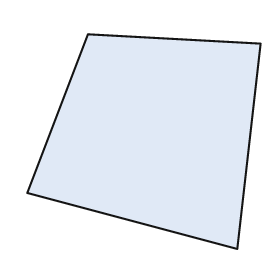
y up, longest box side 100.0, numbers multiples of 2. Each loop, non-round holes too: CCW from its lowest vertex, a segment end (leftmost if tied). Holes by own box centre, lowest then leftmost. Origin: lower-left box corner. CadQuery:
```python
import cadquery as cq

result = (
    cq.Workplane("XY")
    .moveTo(90.0, 0.0)
    .lineTo(100.0, 88.0)
    .lineTo(26.0, 92.0)
    .lineTo(0.0, 24.0)
    .close()
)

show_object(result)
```